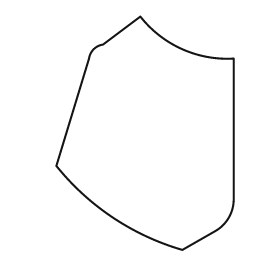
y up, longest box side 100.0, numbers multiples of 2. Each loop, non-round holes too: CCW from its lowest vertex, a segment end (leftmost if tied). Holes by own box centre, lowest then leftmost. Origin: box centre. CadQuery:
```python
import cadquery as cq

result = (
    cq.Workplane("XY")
    .moveTo(16.0, -50.0)
    .lineTo(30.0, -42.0)
    .threePointArc((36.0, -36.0), (38.0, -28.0))
    .lineTo(38.0, 32.0)
    .threePointArc((16.0, 36.0), (-2.0, 50.0))
    .lineTo(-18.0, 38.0)
    .threePointArc((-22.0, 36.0), (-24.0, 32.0))
    .lineTo(-38.0, -14.0)
    .threePointArc((-14.0, -36.0), (16.0, -50.0))
    .close()
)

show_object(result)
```